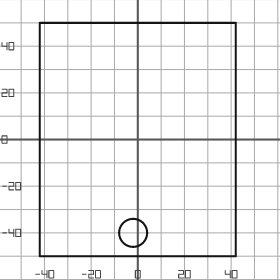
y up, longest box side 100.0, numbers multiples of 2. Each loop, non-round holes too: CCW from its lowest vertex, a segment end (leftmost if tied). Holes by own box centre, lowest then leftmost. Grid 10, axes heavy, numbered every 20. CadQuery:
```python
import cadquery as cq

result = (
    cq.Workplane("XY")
    .moveTo(-42.0, -50.0)
    .lineTo(42.0, -50.0)
    .lineTo(42.0, 50.0)
    .lineTo(-42.0, 50.0)
    .close()
    .moveTo(-2.0, -40.0)
    .circle(6.0)
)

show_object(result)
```